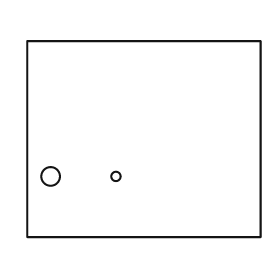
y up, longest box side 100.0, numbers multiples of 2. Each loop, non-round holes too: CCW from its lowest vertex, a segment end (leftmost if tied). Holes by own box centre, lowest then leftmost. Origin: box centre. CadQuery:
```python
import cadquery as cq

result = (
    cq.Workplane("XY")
    .moveTo(-50.0, -42.0)
    .lineTo(50.0, -42.0)
    .lineTo(50.0, 42.0)
    .lineTo(-50.0, 42.0)
    .close()
    .moveTo(-40.0, -16.0)
    .circle(4.0)
    .moveTo(-12.0, -16.0)
    .circle(2.0)
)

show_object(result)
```